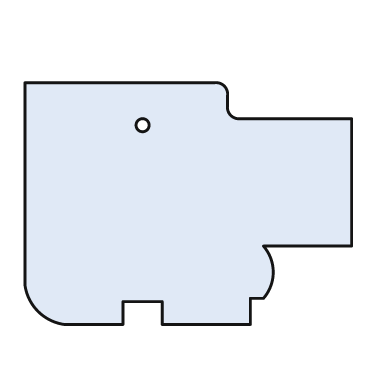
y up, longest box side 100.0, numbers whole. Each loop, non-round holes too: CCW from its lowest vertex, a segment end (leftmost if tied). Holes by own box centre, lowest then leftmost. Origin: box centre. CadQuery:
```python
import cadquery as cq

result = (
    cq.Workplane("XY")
    .moveTo(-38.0, -37.0)
    .lineTo(-20.0, -37.0)
    .lineTo(-20.0, -30.0)
    .lineTo(-8.0, -30.0)
    .lineTo(-8.0, -37.0)
    .lineTo(19.0, -37.0)
    .lineTo(19.0, -29.0)
    .lineTo(23.0, -29.0)
    .threePointArc((26.0, -21.0), (23.0, -13.0))
    .lineTo(50.0, -13.0)
    .lineTo(50.0, 26.0)
    .lineTo(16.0, 26.0)
    .threePointArc((13.0, 27.0), (12.0, 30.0))
    .lineTo(12.0, 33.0)
    .threePointArc((11.0, 36.0), (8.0, 37.0))
    .lineTo(-50.0, 37.0)
    .lineTo(-50.0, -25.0)
    .threePointArc((-46.0, -33.0), (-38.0, -37.0))
    .close()
    .moveTo(-14.0, 24.0)
    .circle(2.0)
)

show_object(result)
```